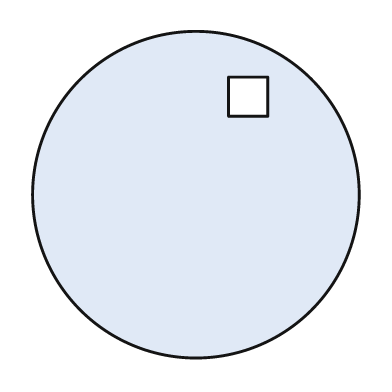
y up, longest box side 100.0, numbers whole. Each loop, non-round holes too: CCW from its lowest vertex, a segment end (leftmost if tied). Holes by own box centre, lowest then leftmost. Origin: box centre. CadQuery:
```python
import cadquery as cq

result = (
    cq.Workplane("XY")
    .moveTo(0.0, 0.0)
    .circle(50.0)
    .moveTo(10.0, 24.0)
    .lineTo(22.0, 24.0)
    .lineTo(22.0, 36.0)
    .lineTo(10.0, 36.0)
    .close()
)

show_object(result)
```